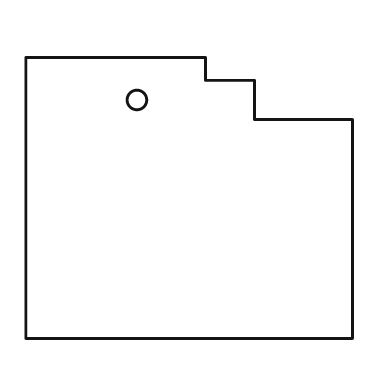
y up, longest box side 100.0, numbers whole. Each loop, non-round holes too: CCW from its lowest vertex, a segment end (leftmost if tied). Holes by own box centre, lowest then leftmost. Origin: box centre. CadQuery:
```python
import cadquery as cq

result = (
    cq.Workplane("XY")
    .moveTo(-50.0, -43.0)
    .lineTo(50.0, -43.0)
    .lineTo(50.0, 24.0)
    .lineTo(20.0, 24.0)
    .lineTo(20.0, 36.0)
    .lineTo(5.0, 36.0)
    .lineTo(5.0, 43.0)
    .lineTo(-50.0, 43.0)
    .close()
    .moveTo(-16.0, 30.0)
    .circle(3.0)
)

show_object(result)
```